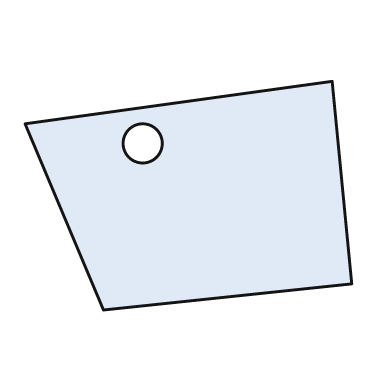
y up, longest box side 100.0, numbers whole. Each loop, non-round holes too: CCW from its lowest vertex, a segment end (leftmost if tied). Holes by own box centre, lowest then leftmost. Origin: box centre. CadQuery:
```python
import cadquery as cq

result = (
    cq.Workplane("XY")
    .moveTo(-26.0, -35.0)
    .lineTo(50.0, -27.0)
    .lineTo(44.0, 35.0)
    .lineTo(-50.0, 22.0)
    .close()
    .moveTo(-14.0, 16.0)
    .circle(6.0)
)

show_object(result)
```